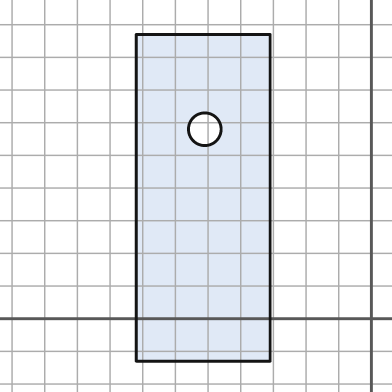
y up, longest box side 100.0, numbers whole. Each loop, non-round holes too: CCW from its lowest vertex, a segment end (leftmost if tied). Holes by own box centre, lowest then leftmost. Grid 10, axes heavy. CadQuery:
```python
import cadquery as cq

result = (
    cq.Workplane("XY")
    .moveTo(-72.0, -13.0)
    .lineTo(-31.0, -13.0)
    .lineTo(-31.0, 87.0)
    .lineTo(-72.0, 87.0)
    .close()
    .moveTo(-51.0, 58.0)
    .circle(5.0)
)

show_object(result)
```